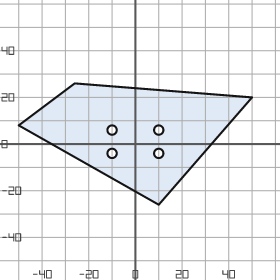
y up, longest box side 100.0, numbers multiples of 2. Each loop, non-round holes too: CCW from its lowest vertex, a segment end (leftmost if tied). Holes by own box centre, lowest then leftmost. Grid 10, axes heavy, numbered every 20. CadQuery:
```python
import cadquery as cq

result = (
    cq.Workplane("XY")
    .moveTo(10.0, -26.0)
    .lineTo(50.0, 20.0)
    .lineTo(-26.0, 26.0)
    .lineTo(-50.0, 8.0)
    .close()
    .moveTo(-10.0, -4.0)
    .circle(2.0)
    .moveTo(10.0, -4.0)
    .circle(2.0)
    .moveTo(-10.0, 6.0)
    .circle(2.0)
    .moveTo(10.0, 6.0)
    .circle(2.0)
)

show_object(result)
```